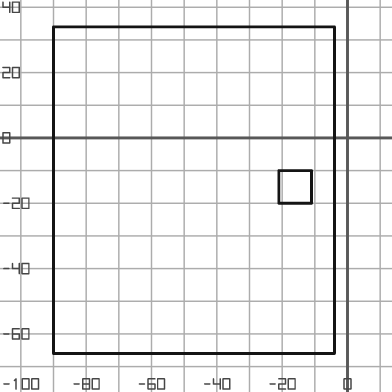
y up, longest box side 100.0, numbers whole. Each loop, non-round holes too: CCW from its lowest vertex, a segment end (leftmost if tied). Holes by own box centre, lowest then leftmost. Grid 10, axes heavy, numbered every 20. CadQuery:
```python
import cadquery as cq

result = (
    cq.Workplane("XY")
    .moveTo(-90.0, -66.0)
    .lineTo(-4.0, -66.0)
    .lineTo(-4.0, 34.0)
    .lineTo(-90.0, 34.0)
    .close()
    .moveTo(-21.0, -20.0)
    .lineTo(-11.0, -20.0)
    .lineTo(-11.0, -10.0)
    .lineTo(-21.0, -10.0)
    .close()
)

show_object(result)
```